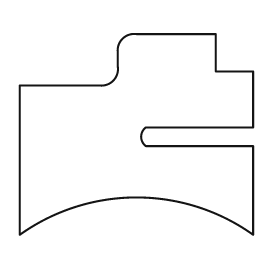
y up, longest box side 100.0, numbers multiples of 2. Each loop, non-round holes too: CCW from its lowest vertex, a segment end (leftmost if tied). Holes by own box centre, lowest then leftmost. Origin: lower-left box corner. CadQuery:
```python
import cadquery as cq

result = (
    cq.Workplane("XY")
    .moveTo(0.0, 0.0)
    .threePointArc((50.0, 16.0), (100.0, 0.0))
    .lineTo(100.0, 38.0)
    .lineTo(54.0, 38.0)
    .threePointArc((52.0, 42.0), (54.0, 46.0))
    .lineTo(100.0, 46.0)
    .lineTo(100.0, 70.0)
    .lineTo(84.0, 70.0)
    .lineTo(84.0, 86.0)
    .lineTo(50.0, 86.0)
    .threePointArc((44.0, 84.0), (42.0, 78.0))
    .lineTo(42.0, 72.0)
    .threePointArc((40.0, 66.0), (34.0, 64.0))
    .lineTo(0.0, 64.0)
    .close()
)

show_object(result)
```